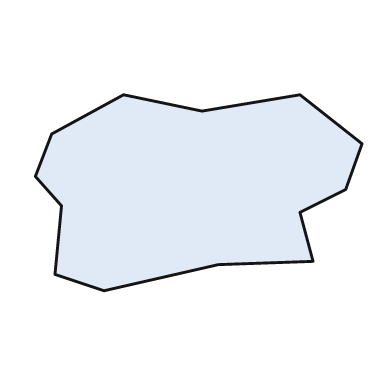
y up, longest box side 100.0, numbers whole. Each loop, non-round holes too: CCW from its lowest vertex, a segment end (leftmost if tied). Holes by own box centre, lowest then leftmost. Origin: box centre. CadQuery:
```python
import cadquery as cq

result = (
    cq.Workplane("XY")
    .moveTo(-29.0, -30.0)
    .lineTo(6.0, -22.0)
    .lineTo(35.0, -21.0)
    .lineTo(31.0, -6.0)
    .lineTo(45.0, 1.0)
    .lineTo(50.0, 15.0)
    .lineTo(31.0, 30.0)
    .lineTo(1.0, 25.0)
    .lineTo(-23.0, 30.0)
    .lineTo(-45.0, 18.0)
    .lineTo(-50.0, 5.0)
    .lineTo(-42.0, -4.0)
    .lineTo(-44.0, -25.0)
    .close()
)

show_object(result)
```